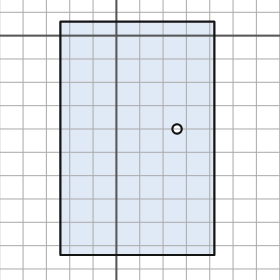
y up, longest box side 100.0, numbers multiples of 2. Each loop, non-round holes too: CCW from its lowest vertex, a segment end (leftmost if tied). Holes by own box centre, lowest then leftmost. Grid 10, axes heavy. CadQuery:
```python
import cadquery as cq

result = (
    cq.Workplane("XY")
    .moveTo(-24.0, -94.0)
    .lineTo(42.0, -94.0)
    .lineTo(42.0, 6.0)
    .lineTo(-24.0, 6.0)
    .close()
    .moveTo(26.0, -40.0)
    .circle(2.0)
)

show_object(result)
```